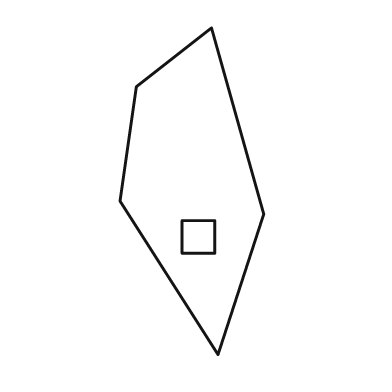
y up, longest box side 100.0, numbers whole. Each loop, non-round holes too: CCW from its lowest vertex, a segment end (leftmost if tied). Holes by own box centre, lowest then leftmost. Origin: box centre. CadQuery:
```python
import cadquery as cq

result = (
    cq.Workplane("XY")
    .moveTo(8.0, -50.0)
    .lineTo(22.0, -7.0)
    .lineTo(6.0, 50.0)
    .lineTo(-17.0, 32.0)
    .lineTo(-22.0, -3.0)
    .close()
    .moveTo(-3.0, -19.0)
    .lineTo(7.0, -19.0)
    .lineTo(7.0, -9.0)
    .lineTo(-3.0, -9.0)
    .close()
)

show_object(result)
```